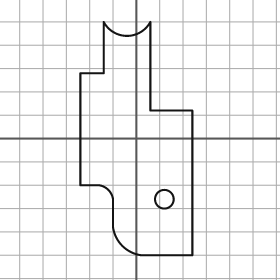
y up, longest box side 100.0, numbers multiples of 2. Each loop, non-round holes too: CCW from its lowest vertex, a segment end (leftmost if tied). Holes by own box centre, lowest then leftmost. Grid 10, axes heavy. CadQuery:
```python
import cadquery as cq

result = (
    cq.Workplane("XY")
    .moveTo(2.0, -50.0)
    .lineTo(24.0, -50.0)
    .lineTo(24.0, 12.0)
    .lineTo(6.0, 12.0)
    .lineTo(6.0, 50.0)
    .threePointArc((-4.0, 44.0), (-14.0, 50.0))
    .lineTo(-14.0, 28.0)
    .lineTo(-24.0, 28.0)
    .lineTo(-24.0, -20.0)
    .lineTo(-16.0, -20.0)
    .threePointArc((-12.0, -22.0), (-10.0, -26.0))
    .lineTo(-10.0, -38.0)
    .threePointArc((-6.0, -46.0), (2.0, -50.0))
    .close()
    .moveTo(12.0, -26.0)
    .circle(4.0)
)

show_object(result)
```